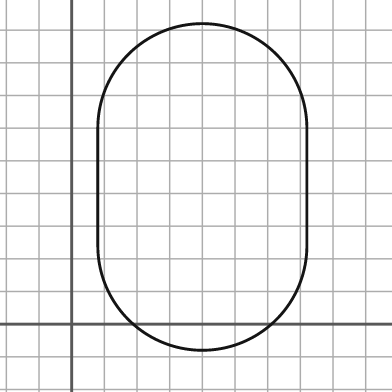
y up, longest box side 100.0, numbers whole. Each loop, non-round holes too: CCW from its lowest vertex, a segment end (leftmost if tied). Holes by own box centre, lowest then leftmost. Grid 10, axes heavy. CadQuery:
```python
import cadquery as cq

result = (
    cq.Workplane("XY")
    .moveTo(8.0, 24.0)
    .threePointArc((40.0, -8.0), (72.0, 24.0))
    .lineTo(72.0, 60.0)
    .threePointArc((40.0, 92.0), (8.0, 60.0))
    .close()
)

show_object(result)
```